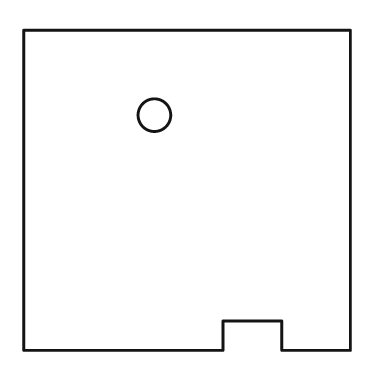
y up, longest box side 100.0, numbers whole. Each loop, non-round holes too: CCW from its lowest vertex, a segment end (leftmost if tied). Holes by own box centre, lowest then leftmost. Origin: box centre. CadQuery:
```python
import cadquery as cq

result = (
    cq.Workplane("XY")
    .moveTo(-50.0, -49.0)
    .lineTo(11.0, -49.0)
    .lineTo(11.0, -40.0)
    .lineTo(29.0, -40.0)
    .lineTo(29.0, -49.0)
    .lineTo(50.0, -49.0)
    .lineTo(50.0, 49.0)
    .lineTo(-50.0, 49.0)
    .close()
    .moveTo(-10.0, 23.0)
    .circle(5.0)
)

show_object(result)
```